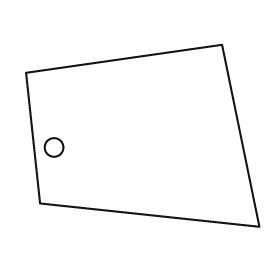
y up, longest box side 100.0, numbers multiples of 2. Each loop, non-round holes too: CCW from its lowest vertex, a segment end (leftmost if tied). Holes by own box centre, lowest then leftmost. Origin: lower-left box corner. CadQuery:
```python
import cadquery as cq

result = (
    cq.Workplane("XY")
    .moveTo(100.0, 0.0)
    .lineTo(84.0, 78.0)
    .lineTo(0.0, 66.0)
    .lineTo(6.0, 10.0)
    .close()
    .moveTo(12.0, 34.0)
    .circle(4.0)
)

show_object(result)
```